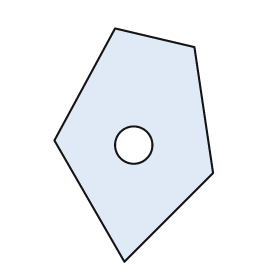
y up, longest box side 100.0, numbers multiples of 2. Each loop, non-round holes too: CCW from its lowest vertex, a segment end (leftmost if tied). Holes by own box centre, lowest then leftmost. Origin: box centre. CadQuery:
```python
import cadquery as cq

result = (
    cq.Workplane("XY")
    .moveTo(-4.0, -50.0)
    .lineTo(34.0, -12.0)
    .lineTo(26.0, 42.0)
    .lineTo(-8.0, 50.0)
    .lineTo(-34.0, 2.0)
    .close()
    .moveTo(0.0, 0.0)
    .circle(8.0)
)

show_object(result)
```